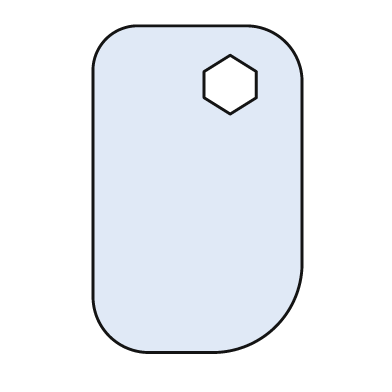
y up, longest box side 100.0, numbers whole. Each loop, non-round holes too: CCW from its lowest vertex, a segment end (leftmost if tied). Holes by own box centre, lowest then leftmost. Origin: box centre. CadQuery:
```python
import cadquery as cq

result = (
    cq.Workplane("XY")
    .moveTo(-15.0, -50.0)
    .lineTo(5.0, -50.0)
    .threePointArc((24.0, -42.0), (32.0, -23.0))
    .lineTo(32.0, 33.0)
    .threePointArc((27.0, 45.0), (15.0, 50.0))
    .lineTo(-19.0, 50.0)
    .threePointArc((-28.0, 46.0), (-32.0, 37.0))
    .lineTo(-32.0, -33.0)
    .threePointArc((-27.0, -45.0), (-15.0, -50.0))
    .close()
    .moveTo(10.0, 23.0)
    .lineTo(18.0, 28.0)
    .lineTo(18.0, 36.0)
    .lineTo(10.0, 41.0)
    .lineTo(2.0, 36.0)
    .lineTo(2.0, 28.0)
    .close()
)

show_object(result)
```